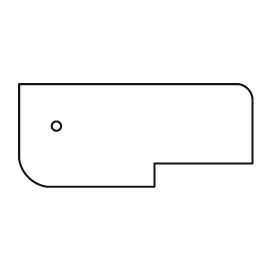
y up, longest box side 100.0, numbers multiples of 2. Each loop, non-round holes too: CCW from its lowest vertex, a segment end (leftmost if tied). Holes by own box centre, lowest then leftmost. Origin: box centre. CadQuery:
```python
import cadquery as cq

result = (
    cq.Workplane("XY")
    .moveTo(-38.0, -22.0)
    .lineTo(8.0, -22.0)
    .lineTo(8.0, -12.0)
    .lineTo(50.0, -12.0)
    .lineTo(50.0, 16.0)
    .threePointArc((48.0, 20.0), (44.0, 22.0))
    .lineTo(-50.0, 22.0)
    .lineTo(-50.0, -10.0)
    .threePointArc((-46.0, -18.0), (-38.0, -22.0))
    .close()
    .moveTo(-34.0, 4.0)
    .circle(2.0)
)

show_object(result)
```